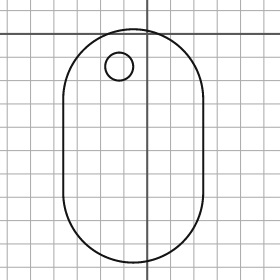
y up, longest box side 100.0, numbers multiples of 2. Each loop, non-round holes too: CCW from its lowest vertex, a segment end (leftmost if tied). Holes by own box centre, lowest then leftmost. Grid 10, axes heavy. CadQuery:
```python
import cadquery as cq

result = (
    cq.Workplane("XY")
    .moveTo(-36.0, -68.0)
    .threePointArc((-6.0, -98.0), (24.0, -68.0))
    .lineTo(24.0, -28.0)
    .threePointArc((-6.0, 2.0), (-36.0, -28.0))
    .close()
    .moveTo(-12.0, -14.0)
    .circle(6.0)
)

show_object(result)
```